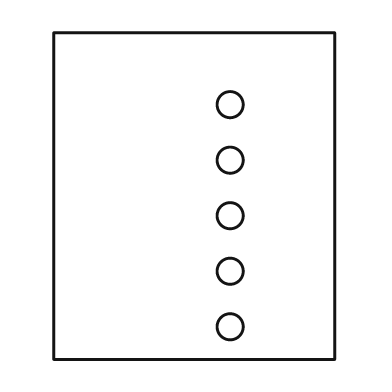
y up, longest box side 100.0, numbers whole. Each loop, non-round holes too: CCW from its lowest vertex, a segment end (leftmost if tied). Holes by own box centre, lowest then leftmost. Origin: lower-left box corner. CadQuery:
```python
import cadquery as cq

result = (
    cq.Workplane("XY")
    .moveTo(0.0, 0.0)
    .lineTo(86.0, 0.0)
    .lineTo(86.0, 100.0)
    .lineTo(0.0, 100.0)
    .close()
    .moveTo(54.0, 10.0)
    .circle(4.0)
    .moveTo(54.0, 27.0)
    .circle(4.0)
    .moveTo(54.0, 44.0)
    .circle(4.0)
    .moveTo(54.0, 61.0)
    .circle(4.0)
    .moveTo(54.0, 78.0)
    .circle(4.0)
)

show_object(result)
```